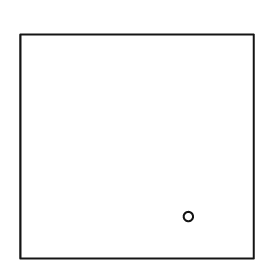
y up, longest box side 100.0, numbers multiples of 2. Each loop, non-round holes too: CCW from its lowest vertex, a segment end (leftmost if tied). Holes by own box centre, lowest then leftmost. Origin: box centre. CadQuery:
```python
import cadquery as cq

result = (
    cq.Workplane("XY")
    .moveTo(-50.0, -48.0)
    .lineTo(50.0, -48.0)
    .lineTo(50.0, 48.0)
    .lineTo(-50.0, 48.0)
    .close()
    .moveTo(22.0, -30.0)
    .circle(2.0)
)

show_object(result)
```